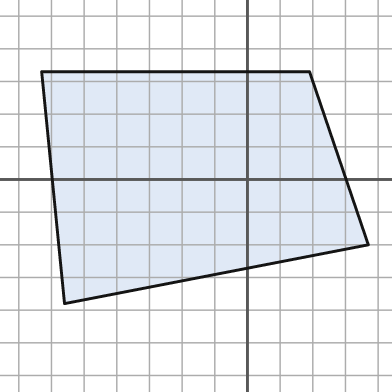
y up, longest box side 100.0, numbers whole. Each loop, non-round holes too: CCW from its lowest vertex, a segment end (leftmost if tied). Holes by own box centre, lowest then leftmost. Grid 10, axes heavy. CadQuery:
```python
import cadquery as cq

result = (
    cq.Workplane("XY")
    .moveTo(-56.0, -38.0)
    .lineTo(37.0, -20.0)
    .lineTo(19.0, 33.0)
    .lineTo(-63.0, 33.0)
    .close()
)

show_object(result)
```